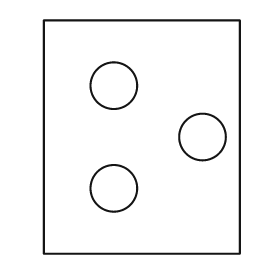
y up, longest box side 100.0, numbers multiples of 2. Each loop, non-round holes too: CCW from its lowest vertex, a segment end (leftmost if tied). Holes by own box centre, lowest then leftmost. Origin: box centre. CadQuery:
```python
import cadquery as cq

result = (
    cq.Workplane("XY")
    .moveTo(-42.0, -50.0)
    .lineTo(42.0, -50.0)
    .lineTo(42.0, 50.0)
    .lineTo(-42.0, 50.0)
    .close()
    .moveTo(-12.0, -22.0)
    .circle(10.0)
    .moveTo(26.0, 0.0)
    .circle(10.0)
    .moveTo(-12.0, 22.0)
    .circle(10.0)
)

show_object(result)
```